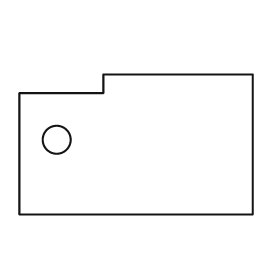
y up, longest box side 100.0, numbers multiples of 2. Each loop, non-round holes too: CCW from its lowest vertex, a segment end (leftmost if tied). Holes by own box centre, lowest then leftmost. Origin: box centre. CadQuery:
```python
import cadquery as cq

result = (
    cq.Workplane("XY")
    .moveTo(-50.0, -30.0)
    .lineTo(50.0, -30.0)
    .lineTo(50.0, 30.0)
    .lineTo(-14.0, 30.0)
    .lineTo(-14.0, 22.0)
    .lineTo(-50.0, 22.0)
    .close()
    .moveTo(-34.0, 2.0)
    .circle(6.0)
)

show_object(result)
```